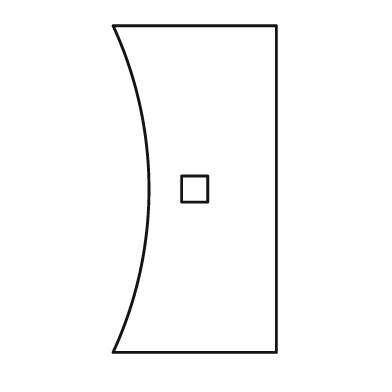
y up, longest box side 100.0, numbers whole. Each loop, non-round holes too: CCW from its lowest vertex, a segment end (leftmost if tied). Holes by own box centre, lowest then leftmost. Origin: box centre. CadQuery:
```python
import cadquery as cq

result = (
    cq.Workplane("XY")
    .moveTo(-25.0, -50.0)
    .lineTo(25.0, -50.0)
    .lineTo(25.0, 50.0)
    .lineTo(-25.0, 50.0)
    .threePointArc((-14.0, 0.0), (-25.0, -50.0))
    .close()
    .moveTo(-4.0, -4.0)
    .lineTo(4.0, -4.0)
    .lineTo(4.0, 4.0)
    .lineTo(-4.0, 4.0)
    .close()
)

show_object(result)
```